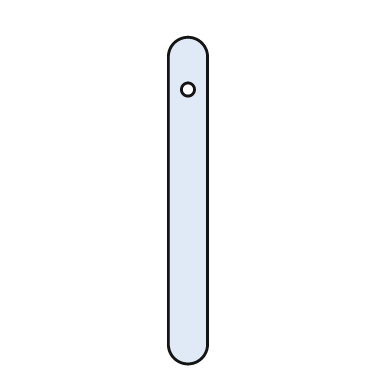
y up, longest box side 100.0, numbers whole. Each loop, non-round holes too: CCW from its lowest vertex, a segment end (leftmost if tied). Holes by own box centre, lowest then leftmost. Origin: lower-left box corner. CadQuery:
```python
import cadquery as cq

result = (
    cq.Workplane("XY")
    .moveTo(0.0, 6.0)
    .threePointArc((6.0, 0.0), (12.0, 6.0))
    .lineTo(12.0, 94.0)
    .threePointArc((6.0, 100.0), (0.0, 94.0))
    .close()
    .moveTo(6.0, 84.0)
    .circle(2.0)
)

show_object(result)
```